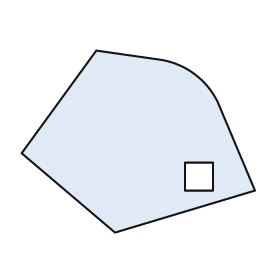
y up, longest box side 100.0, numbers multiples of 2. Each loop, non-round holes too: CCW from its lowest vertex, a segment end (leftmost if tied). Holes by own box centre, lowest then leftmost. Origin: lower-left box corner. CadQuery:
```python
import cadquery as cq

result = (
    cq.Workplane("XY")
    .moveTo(40.0, 0.0)
    .lineTo(100.0, 18.0)
    .lineTo(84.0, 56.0)
    .threePointArc((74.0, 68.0), (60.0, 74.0))
    .lineTo(32.0, 78.0)
    .lineTo(0.0, 34.0)
    .close()
    .moveTo(70.0, 18.0)
    .lineTo(82.0, 18.0)
    .lineTo(82.0, 30.0)
    .lineTo(70.0, 30.0)
    .close()
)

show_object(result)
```